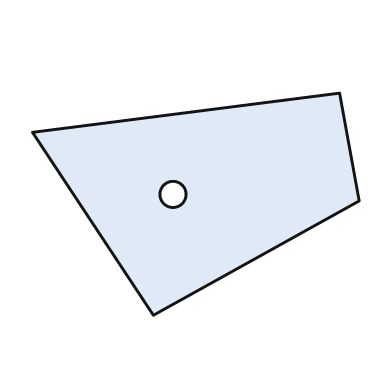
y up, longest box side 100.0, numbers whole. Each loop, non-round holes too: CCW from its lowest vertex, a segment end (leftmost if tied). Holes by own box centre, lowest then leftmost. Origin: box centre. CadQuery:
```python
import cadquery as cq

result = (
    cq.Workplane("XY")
    .moveTo(-13.0, -34.0)
    .lineTo(50.0, 1.0)
    .lineTo(44.0, 34.0)
    .lineTo(-50.0, 22.0)
    .close()
    .moveTo(-7.0, 3.0)
    .circle(4.0)
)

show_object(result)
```